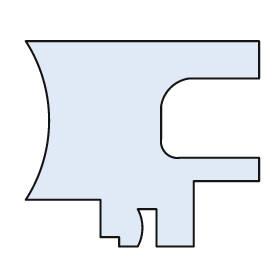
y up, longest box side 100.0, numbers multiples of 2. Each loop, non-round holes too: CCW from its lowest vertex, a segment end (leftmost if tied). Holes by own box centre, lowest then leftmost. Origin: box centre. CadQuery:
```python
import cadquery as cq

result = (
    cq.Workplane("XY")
    .moveTo(-10.0, -44.0)
    .lineTo(-2.0, -44.0)
    .threePointArc((0.0, -36.0), (-2.0, -28.0))
    .lineTo(6.0, -28.0)
    .lineTo(6.0, -44.0)
    .lineTo(22.0, -44.0)
    .lineTo(22.0, -16.0)
    .lineTo(50.0, -16.0)
    .lineTo(50.0, -6.0)
    .lineTo(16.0, -6.0)
    .threePointArc((10.0, -4.0), (8.0, 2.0))
    .lineTo(8.0, 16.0)
    .threePointArc((12.0, 24.0), (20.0, 28.0))
    .lineTo(50.0, 28.0)
    .lineTo(50.0, 44.0)
    .lineTo(-50.0, 44.0)
    .threePointArc((-40.0, 10.0), (-50.0, -24.0))
    .lineTo(-18.0, -24.0)
    .lineTo(-18.0, -40.0)
    .lineTo(-10.0, -40.0)
    .close()
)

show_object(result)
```